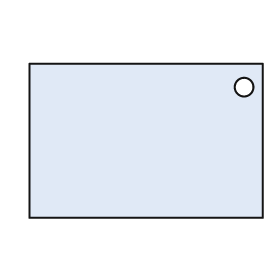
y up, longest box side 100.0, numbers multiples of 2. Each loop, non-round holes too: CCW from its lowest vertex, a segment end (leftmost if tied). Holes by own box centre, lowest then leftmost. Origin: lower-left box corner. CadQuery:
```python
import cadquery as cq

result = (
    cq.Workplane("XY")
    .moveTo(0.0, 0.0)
    .lineTo(100.0, 0.0)
    .lineTo(100.0, 66.0)
    .lineTo(0.0, 66.0)
    .close()
    .moveTo(92.0, 56.0)
    .circle(4.0)
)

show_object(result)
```